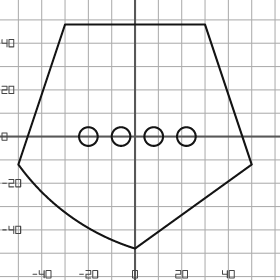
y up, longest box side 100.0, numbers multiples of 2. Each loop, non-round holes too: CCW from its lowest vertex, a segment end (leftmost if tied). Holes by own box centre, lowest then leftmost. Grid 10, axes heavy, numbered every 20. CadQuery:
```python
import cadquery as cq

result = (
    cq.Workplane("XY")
    .moveTo(0.0, -48.0)
    .lineTo(50.0, -12.0)
    .lineTo(30.0, 48.0)
    .lineTo(-30.0, 48.0)
    .lineTo(-50.0, -12.0)
    .threePointArc((-28.0, -34.0), (0.0, -48.0))
    .close()
    .moveTo(-20.0, 0.0)
    .circle(4.0)
    .moveTo(-6.0, 0.0)
    .circle(4.0)
    .moveTo(8.0, 0.0)
    .circle(4.0)
    .moveTo(22.0, 0.0)
    .circle(4.0)
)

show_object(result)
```